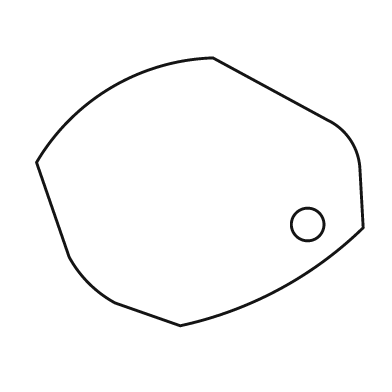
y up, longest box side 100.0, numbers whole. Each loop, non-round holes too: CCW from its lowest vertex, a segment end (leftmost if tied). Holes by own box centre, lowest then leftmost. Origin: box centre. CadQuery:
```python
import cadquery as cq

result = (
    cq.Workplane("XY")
    .moveTo(-6.0, -41.0)
    .threePointArc((24.0, -30.0), (50.0, -11.0))
    .lineTo(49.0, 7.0)
    .threePointArc((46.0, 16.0), (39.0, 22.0))
    .lineTo(4.0, 41.0)
    .threePointArc((-27.0, 32.0), (-50.0, 9.0))
    .lineTo(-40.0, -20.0)
    .threePointArc((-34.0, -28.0), (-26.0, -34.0))
    .close()
    .moveTo(33.0, -10.0)
    .circle(5.0)
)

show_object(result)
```